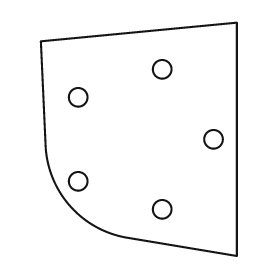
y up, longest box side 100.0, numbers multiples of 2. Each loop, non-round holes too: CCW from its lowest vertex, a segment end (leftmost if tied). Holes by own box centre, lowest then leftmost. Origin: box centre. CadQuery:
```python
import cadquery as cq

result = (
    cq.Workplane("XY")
    .moveTo(42.0, -50.0)
    .lineTo(42.0, 50.0)
    .lineTo(-42.0, 42.0)
    .lineTo(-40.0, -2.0)
    .threePointArc((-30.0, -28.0), (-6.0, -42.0))
    .close()
    .moveTo(10.0, -30.0)
    .circle(4.0)
    .moveTo(-26.0, -18.0)
    .circle(4.0)
    .moveTo(32.0, 0.0)
    .circle(4.0)
    .moveTo(-26.0, 18.0)
    .circle(4.0)
    .moveTo(10.0, 30.0)
    .circle(4.0)
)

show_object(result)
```